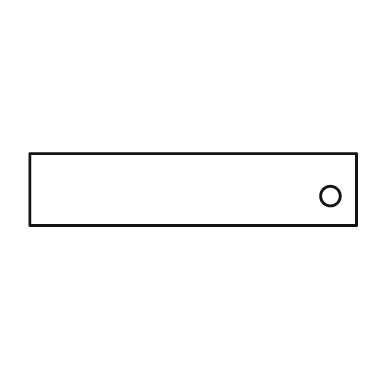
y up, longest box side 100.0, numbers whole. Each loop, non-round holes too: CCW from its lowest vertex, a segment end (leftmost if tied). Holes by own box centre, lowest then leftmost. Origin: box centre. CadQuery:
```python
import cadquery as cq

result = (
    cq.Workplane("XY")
    .moveTo(-50.0, -11.0)
    .lineTo(50.0, -11.0)
    .lineTo(50.0, 11.0)
    .lineTo(-50.0, 11.0)
    .close()
    .moveTo(42.0, -2.0)
    .circle(3.0)
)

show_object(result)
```